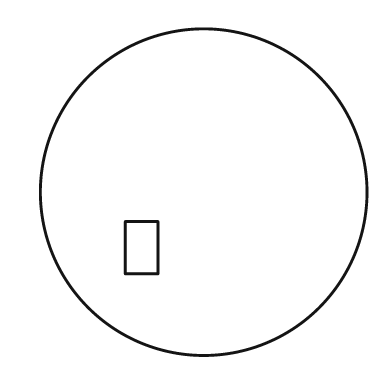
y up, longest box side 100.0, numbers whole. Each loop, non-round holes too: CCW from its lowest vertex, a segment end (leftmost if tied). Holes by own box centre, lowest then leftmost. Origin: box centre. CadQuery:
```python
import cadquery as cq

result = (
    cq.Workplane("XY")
    .moveTo(0.0, 0.0)
    .circle(50.0)
    .moveTo(-24.0, -25.0)
    .lineTo(-14.0, -25.0)
    .lineTo(-14.0, -9.0)
    .lineTo(-24.0, -9.0)
    .close()
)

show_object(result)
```